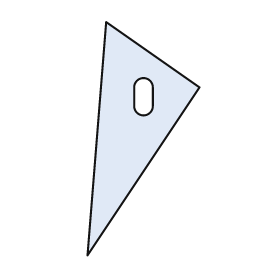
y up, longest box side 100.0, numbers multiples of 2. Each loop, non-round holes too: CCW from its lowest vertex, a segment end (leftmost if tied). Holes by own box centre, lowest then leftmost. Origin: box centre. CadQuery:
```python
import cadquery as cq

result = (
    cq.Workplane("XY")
    .moveTo(-24.0, -50.0)
    .lineTo(24.0, 22.0)
    .lineTo(-16.0, 50.0)
    .close()
    .moveTo(-4.0, 14.0)
    .threePointArc((0.0, 10.0), (4.0, 14.0))
    .lineTo(4.0, 22.0)
    .threePointArc((0.0, 26.0), (-4.0, 22.0))
    .close()
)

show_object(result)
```